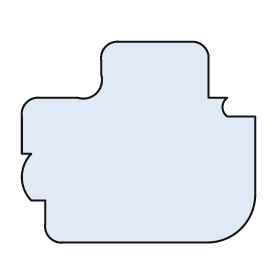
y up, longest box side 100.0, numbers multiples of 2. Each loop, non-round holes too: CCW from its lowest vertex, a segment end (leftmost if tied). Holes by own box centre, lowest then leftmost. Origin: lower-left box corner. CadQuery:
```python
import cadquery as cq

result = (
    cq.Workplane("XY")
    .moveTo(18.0, 0.0)
    .lineTo(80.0, 0.0)
    .threePointArc((94.0, 6.0), (100.0, 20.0))
    .lineTo(100.0, 54.0)
    .lineTo(88.0, 54.0)
    .threePointArc((86.0, 58.0), (88.0, 62.0))
    .lineTo(80.0, 62.0)
    .lineTo(80.0, 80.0)
    .threePointArc((78.0, 84.0), (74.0, 86.0))
    .lineTo(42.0, 86.0)
    .threePointArc((36.0, 84.0), (34.0, 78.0))
    .lineTo(34.0, 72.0)
    .threePointArc((32.0, 64.0), (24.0, 62.0))
    .lineTo(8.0, 62.0)
    .threePointArc((2.0, 60.0), (0.0, 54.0))
    .lineTo(0.0, 38.0)
    .lineTo(4.0, 38.0)
    .threePointArc((0.0, 28.0), (4.0, 18.0))
    .lineTo(10.0, 18.0)
    .lineTo(10.0, 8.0)
    .threePointArc((12.0, 2.0), (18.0, 0.0))
    .close()
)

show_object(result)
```